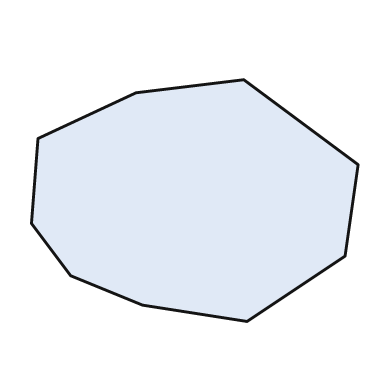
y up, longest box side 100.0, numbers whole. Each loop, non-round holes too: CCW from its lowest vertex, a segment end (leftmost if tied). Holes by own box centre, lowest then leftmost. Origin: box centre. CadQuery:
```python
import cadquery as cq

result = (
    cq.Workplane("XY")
    .moveTo(16.0, -37.0)
    .lineTo(46.0, -17.0)
    .lineTo(50.0, 11.0)
    .lineTo(15.0, 37.0)
    .lineTo(-18.0, 33.0)
    .lineTo(-48.0, 19.0)
    .lineTo(-50.0, -7.0)
    .lineTo(-38.0, -23.0)
    .lineTo(-16.0, -32.0)
    .close()
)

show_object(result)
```